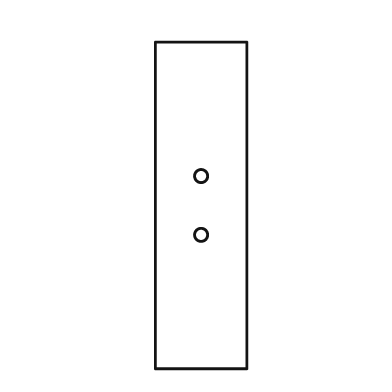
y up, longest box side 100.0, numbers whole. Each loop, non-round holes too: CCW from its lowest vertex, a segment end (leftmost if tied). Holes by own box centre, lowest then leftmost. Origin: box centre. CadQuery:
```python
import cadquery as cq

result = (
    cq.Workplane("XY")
    .moveTo(-14.0, -50.0)
    .lineTo(14.0, -50.0)
    .lineTo(14.0, 50.0)
    .lineTo(-14.0, 50.0)
    .close()
    .moveTo(0.0, -9.0)
    .circle(2.0)
    .moveTo(0.0, 9.0)
    .circle(2.0)
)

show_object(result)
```